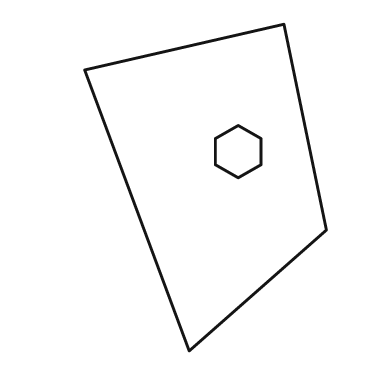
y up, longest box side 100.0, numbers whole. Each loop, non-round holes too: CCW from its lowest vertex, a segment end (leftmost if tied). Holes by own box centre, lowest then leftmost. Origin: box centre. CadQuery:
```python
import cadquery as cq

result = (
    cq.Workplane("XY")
    .moveTo(-5.0, -50.0)
    .lineTo(37.0, -13.0)
    .lineTo(24.0, 50.0)
    .lineTo(-37.0, 36.0)
    .close()
    .moveTo(10.0, 3.0)
    .lineTo(17.0, 7.0)
    .lineTo(17.0, 15.0)
    .lineTo(10.0, 19.0)
    .lineTo(3.0, 15.0)
    .lineTo(3.0, 7.0)
    .close()
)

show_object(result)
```